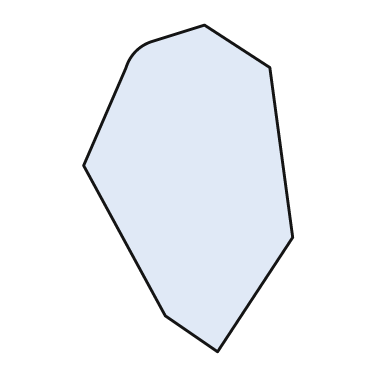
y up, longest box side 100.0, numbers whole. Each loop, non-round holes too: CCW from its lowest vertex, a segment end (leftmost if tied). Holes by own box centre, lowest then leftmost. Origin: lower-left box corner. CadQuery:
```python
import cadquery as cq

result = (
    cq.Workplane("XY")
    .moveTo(41.0, 0.0)
    .lineTo(64.0, 35.0)
    .lineTo(57.0, 87.0)
    .lineTo(37.0, 100.0)
    .lineTo(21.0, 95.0)
    .threePointArc((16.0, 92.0), (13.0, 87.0))
    .lineTo(0.0, 57.0)
    .lineTo(25.0, 11.0)
    .close()
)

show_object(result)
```